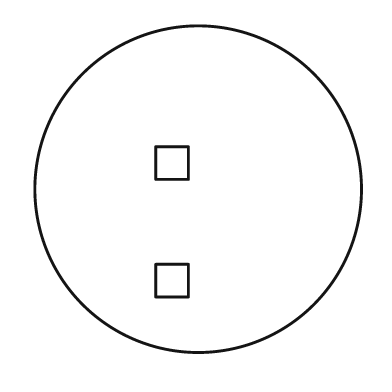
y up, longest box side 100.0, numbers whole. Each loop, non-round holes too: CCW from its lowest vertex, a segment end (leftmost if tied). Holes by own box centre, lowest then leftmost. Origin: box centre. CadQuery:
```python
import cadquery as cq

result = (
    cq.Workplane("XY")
    .moveTo(0.0, 0.0)
    .circle(50.0)
    .moveTo(-13.0, -33.0)
    .lineTo(-3.0, -33.0)
    .lineTo(-3.0, -23.0)
    .lineTo(-13.0, -23.0)
    .close()
    .moveTo(-13.0, 3.0)
    .lineTo(-3.0, 3.0)
    .lineTo(-3.0, 13.0)
    .lineTo(-13.0, 13.0)
    .close()
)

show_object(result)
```